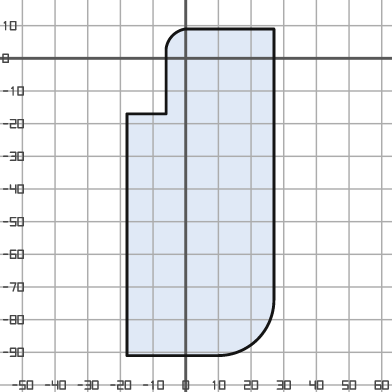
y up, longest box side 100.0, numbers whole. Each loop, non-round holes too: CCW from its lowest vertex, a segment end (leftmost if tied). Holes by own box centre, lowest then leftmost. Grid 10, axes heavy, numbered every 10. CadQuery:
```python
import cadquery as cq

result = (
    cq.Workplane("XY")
    .moveTo(-18.0, -91.0)
    .lineTo(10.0, -91.0)
    .threePointArc((22.0, -86.0), (27.0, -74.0))
    .lineTo(27.0, 9.0)
    .lineTo(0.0, 9.0)
    .threePointArc((-4.0, 7.0), (-6.0, 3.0))
    .lineTo(-6.0, -17.0)
    .lineTo(-18.0, -17.0)
    .close()
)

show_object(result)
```